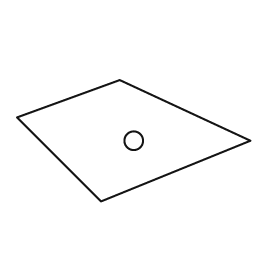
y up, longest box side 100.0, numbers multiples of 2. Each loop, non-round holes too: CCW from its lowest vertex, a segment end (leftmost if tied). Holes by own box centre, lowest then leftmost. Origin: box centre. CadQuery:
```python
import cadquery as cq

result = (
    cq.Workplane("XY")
    .moveTo(-14.0, -26.0)
    .lineTo(50.0, 0.0)
    .lineTo(-6.0, 26.0)
    .lineTo(-50.0, 10.0)
    .close()
    .moveTo(0.0, 0.0)
    .circle(4.0)
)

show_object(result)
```